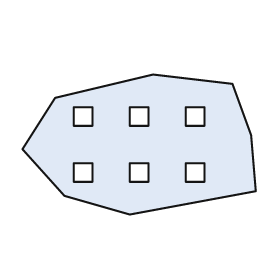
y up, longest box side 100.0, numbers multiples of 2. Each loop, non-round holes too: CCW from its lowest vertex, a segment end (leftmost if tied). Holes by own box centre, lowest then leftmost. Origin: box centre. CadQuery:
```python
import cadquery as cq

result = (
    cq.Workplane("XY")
    .moveTo(-4.0, -30.0)
    .lineTo(50.0, -20.0)
    .lineTo(48.0, 4.0)
    .lineTo(40.0, 26.0)
    .lineTo(6.0, 30.0)
    .lineTo(-36.0, 20.0)
    .lineTo(-50.0, -2.0)
    .lineTo(-32.0, -22.0)
    .close()
    .moveTo(-28.0, -16.0)
    .lineTo(-20.0, -16.0)
    .lineTo(-20.0, -8.0)
    .lineTo(-28.0, -8.0)
    .close()
    .moveTo(-4.0, -16.0)
    .lineTo(4.0, -16.0)
    .lineTo(4.0, -8.0)
    .lineTo(-4.0, -8.0)
    .close()
    .moveTo(20.0, -16.0)
    .lineTo(28.0, -16.0)
    .lineTo(28.0, -8.0)
    .lineTo(20.0, -8.0)
    .close()
    .moveTo(-28.0, 8.0)
    .lineTo(-20.0, 8.0)
    .lineTo(-20.0, 16.0)
    .lineTo(-28.0, 16.0)
    .close()
    .moveTo(-4.0, 8.0)
    .lineTo(4.0, 8.0)
    .lineTo(4.0, 16.0)
    .lineTo(-4.0, 16.0)
    .close()
    .moveTo(20.0, 8.0)
    .lineTo(28.0, 8.0)
    .lineTo(28.0, 16.0)
    .lineTo(20.0, 16.0)
    .close()
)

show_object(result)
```